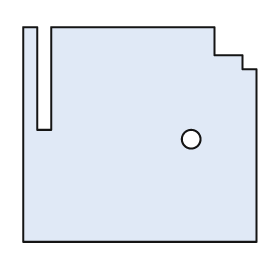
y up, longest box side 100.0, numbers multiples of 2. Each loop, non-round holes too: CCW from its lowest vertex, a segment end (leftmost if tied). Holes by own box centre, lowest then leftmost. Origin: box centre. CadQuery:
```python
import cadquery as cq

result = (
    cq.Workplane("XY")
    .moveTo(-50.0, -46.0)
    .lineTo(50.0, -46.0)
    .lineTo(50.0, 28.0)
    .lineTo(44.0, 28.0)
    .lineTo(44.0, 34.0)
    .lineTo(32.0, 34.0)
    .lineTo(32.0, 46.0)
    .lineTo(-38.0, 46.0)
    .lineTo(-38.0, 2.0)
    .lineTo(-44.0, 2.0)
    .lineTo(-44.0, 46.0)
    .lineTo(-50.0, 46.0)
    .close()
    .moveTo(22.0, -2.0)
    .circle(4.0)
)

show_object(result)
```